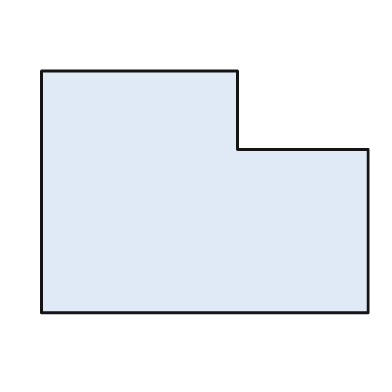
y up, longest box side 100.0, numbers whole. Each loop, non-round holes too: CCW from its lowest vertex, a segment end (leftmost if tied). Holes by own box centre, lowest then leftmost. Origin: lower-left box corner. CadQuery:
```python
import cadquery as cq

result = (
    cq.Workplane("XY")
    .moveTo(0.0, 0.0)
    .lineTo(100.0, 0.0)
    .lineTo(100.0, 50.0)
    .lineTo(60.0, 50.0)
    .lineTo(60.0, 74.0)
    .lineTo(0.0, 74.0)
    .close()
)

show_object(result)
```